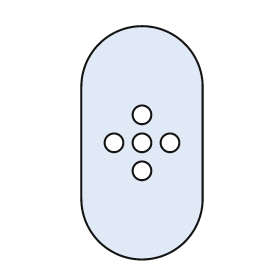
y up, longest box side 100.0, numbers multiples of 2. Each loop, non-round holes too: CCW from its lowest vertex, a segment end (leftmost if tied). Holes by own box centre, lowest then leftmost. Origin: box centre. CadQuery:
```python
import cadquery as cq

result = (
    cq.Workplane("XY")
    .moveTo(-26.0, -24.0)
    .threePointArc((0.0, -50.0), (26.0, -24.0))
    .lineTo(26.0, 24.0)
    .threePointArc((0.0, 50.0), (-26.0, 24.0))
    .close()
    .moveTo(0.0, -12.0)
    .circle(4.0)
    .moveTo(-12.0, 0.0)
    .circle(4.0)
    .moveTo(0.0, 0.0)
    .circle(4.0)
    .moveTo(12.0, 0.0)
    .circle(4.0)
    .moveTo(0.0, 12.0)
    .circle(4.0)
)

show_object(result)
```